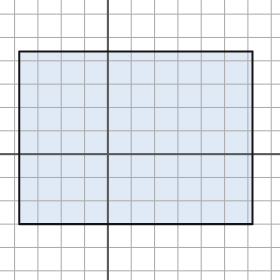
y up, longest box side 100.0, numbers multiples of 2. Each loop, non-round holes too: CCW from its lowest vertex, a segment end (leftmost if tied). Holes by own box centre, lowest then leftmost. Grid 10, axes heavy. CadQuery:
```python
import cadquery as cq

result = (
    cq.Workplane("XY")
    .moveTo(-38.0, -30.0)
    .lineTo(62.0, -30.0)
    .lineTo(62.0, 44.0)
    .lineTo(-38.0, 44.0)
    .close()
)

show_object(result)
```